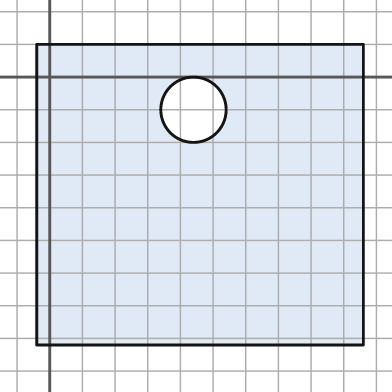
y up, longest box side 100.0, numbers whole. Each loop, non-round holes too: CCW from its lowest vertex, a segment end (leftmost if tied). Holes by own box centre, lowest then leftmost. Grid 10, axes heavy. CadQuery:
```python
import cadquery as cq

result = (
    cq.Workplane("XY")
    .moveTo(-4.0, -82.0)
    .lineTo(96.0, -82.0)
    .lineTo(96.0, 10.0)
    .lineTo(-4.0, 10.0)
    .close()
    .moveTo(44.0, -10.0)
    .circle(10.0)
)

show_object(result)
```